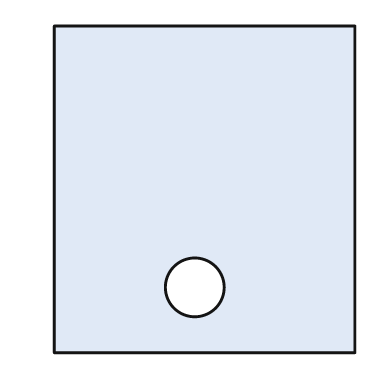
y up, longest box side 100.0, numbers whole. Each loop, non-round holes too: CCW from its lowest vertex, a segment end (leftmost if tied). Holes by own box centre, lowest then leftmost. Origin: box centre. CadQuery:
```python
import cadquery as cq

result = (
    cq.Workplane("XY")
    .moveTo(-46.0, -50.0)
    .lineTo(46.0, -50.0)
    .lineTo(46.0, 50.0)
    .lineTo(-46.0, 50.0)
    .close()
    .moveTo(-3.0, -30.0)
    .circle(9.0)
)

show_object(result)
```